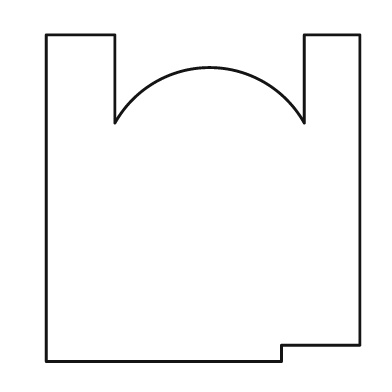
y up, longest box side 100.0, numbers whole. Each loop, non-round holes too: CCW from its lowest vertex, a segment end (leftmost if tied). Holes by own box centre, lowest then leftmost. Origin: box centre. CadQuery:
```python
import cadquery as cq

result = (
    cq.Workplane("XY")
    .moveTo(-48.0, -50.0)
    .lineTo(24.0, -50.0)
    .lineTo(24.0, -45.0)
    .lineTo(48.0, -45.0)
    .lineTo(48.0, 50.0)
    .lineTo(31.0, 50.0)
    .lineTo(31.0, 23.0)
    .threePointArc((2.0, 40.0), (-27.0, 23.0))
    .lineTo(-27.0, 50.0)
    .lineTo(-48.0, 50.0)
    .close()
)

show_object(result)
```